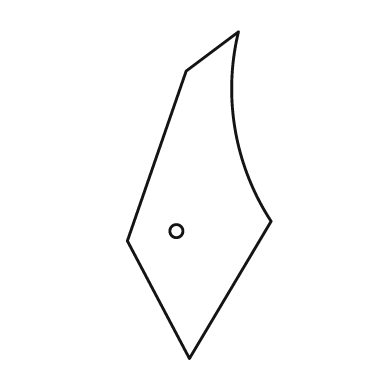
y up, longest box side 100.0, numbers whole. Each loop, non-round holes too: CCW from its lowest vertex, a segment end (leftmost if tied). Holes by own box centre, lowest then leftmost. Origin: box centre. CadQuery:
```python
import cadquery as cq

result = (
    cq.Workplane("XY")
    .moveTo(-3.0, -50.0)
    .lineTo(22.0, -8.0)
    .threePointArc((11.0, 20.0), (12.0, 50.0))
    .lineTo(-4.0, 38.0)
    .lineTo(-22.0, -14.0)
    .close()
    .moveTo(-7.0, -11.0)
    .circle(2.0)
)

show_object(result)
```